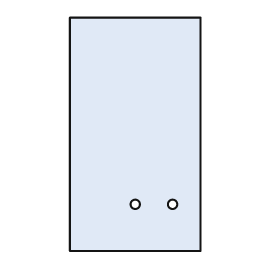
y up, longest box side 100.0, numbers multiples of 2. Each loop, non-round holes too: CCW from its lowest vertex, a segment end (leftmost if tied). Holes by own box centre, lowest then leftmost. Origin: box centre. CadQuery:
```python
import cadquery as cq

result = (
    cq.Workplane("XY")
    .moveTo(-28.0, -50.0)
    .lineTo(28.0, -50.0)
    .lineTo(28.0, 50.0)
    .lineTo(-28.0, 50.0)
    .close()
    .moveTo(0.0, -30.0)
    .circle(2.0)
    .moveTo(16.0, -30.0)
    .circle(2.0)
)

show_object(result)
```